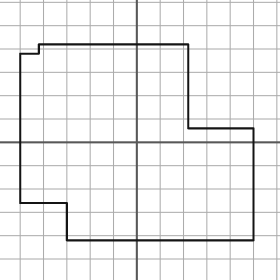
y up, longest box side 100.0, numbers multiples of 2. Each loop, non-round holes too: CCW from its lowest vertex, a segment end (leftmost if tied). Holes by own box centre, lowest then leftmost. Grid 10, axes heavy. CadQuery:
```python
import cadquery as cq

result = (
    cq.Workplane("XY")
    .moveTo(-30.0, -42.0)
    .lineTo(50.0, -42.0)
    .lineTo(50.0, 6.0)
    .lineTo(22.0, 6.0)
    .lineTo(22.0, 42.0)
    .lineTo(-42.0, 42.0)
    .lineTo(-42.0, 38.0)
    .lineTo(-50.0, 38.0)
    .lineTo(-50.0, -26.0)
    .lineTo(-30.0, -26.0)
    .close()
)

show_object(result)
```